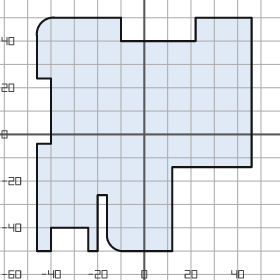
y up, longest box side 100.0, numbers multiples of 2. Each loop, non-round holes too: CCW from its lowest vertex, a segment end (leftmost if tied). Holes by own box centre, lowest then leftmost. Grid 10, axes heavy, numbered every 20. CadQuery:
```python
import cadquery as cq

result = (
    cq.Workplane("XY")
    .moveTo(-46.0, -50.0)
    .lineTo(-40.0, -50.0)
    .lineTo(-40.0, -40.0)
    .lineTo(-24.0, -40.0)
    .lineTo(-24.0, -50.0)
    .lineTo(-20.0, -50.0)
    .lineTo(-20.0, -26.0)
    .lineTo(-16.0, -26.0)
    .lineTo(-16.0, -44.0)
    .threePointArc((-14.0, -48.0), (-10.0, -50.0))
    .lineTo(12.0, -50.0)
    .lineTo(12.0, -14.0)
    .lineTo(46.0, -14.0)
    .lineTo(46.0, 50.0)
    .lineTo(22.0, 50.0)
    .lineTo(22.0, 40.0)
    .lineTo(-10.0, 40.0)
    .lineTo(-10.0, 50.0)
    .lineTo(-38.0, 50.0)
    .threePointArc((-44.0, 48.0), (-46.0, 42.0))
    .lineTo(-46.0, 24.0)
    .lineTo(-40.0, 24.0)
    .lineTo(-40.0, -4.0)
    .lineTo(-46.0, -4.0)
    .close()
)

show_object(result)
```